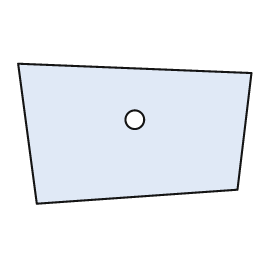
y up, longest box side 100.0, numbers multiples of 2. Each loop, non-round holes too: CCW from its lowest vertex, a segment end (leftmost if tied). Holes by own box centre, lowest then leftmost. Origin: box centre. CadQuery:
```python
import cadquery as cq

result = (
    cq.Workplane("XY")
    .moveTo(-42.0, -30.0)
    .lineTo(44.0, -24.0)
    .lineTo(50.0, 26.0)
    .lineTo(-50.0, 30.0)
    .close()
    .moveTo(0.0, 6.0)
    .circle(4.0)
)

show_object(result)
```